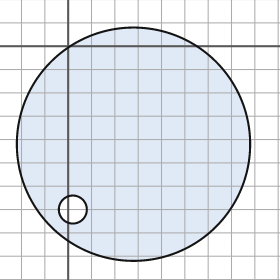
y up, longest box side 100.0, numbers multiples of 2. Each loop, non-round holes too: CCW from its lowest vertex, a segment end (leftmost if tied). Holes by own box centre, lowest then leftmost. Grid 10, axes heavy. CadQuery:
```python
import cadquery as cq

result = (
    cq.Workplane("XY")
    .moveTo(28.0, -42.0)
    .circle(50.0)
    .moveTo(2.0, -70.0)
    .circle(6.0)
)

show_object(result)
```